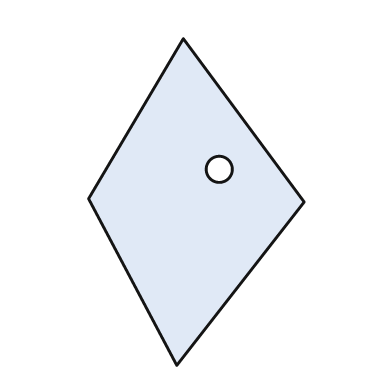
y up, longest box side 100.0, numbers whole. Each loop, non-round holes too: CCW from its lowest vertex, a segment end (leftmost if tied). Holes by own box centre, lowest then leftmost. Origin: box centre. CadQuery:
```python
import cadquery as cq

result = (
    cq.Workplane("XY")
    .moveTo(-6.0, -50.0)
    .lineTo(33.0, 0.0)
    .lineTo(-4.0, 50.0)
    .lineTo(-33.0, 1.0)
    .close()
    .moveTo(7.0, 10.0)
    .circle(4.0)
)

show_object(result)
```